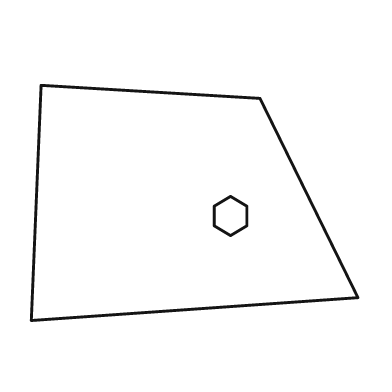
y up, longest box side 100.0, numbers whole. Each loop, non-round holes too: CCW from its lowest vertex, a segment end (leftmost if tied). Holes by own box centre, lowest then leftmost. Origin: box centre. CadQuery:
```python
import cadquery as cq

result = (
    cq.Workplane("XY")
    .moveTo(-50.0, -36.0)
    .lineTo(50.0, -29.0)
    .lineTo(20.0, 32.0)
    .lineTo(-47.0, 36.0)
    .close()
    .moveTo(11.0, -10.0)
    .lineTo(16.0, -7.0)
    .lineTo(16.0, -1.0)
    .lineTo(11.0, 2.0)
    .lineTo(6.0, -1.0)
    .lineTo(6.0, -7.0)
    .close()
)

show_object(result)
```